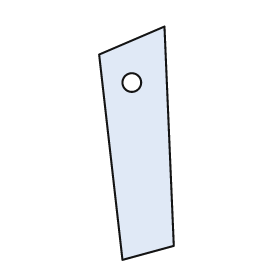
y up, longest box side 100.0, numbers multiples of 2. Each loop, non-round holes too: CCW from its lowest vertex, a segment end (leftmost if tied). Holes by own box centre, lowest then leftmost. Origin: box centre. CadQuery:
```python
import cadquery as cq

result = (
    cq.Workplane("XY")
    .moveTo(-6.0, -50.0)
    .lineTo(16.0, -44.0)
    .lineTo(12.0, 50.0)
    .lineTo(-16.0, 38.0)
    .close()
    .moveTo(-2.0, 26.0)
    .circle(4.0)
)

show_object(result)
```